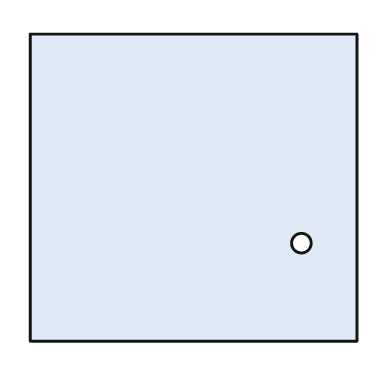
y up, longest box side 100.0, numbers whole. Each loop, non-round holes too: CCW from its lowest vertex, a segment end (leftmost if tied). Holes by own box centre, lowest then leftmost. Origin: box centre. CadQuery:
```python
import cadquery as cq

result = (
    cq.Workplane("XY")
    .moveTo(-50.0, -47.0)
    .lineTo(50.0, -47.0)
    .lineTo(50.0, 47.0)
    .lineTo(-50.0, 47.0)
    .close()
    .moveTo(33.0, -17.0)
    .circle(3.0)
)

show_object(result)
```